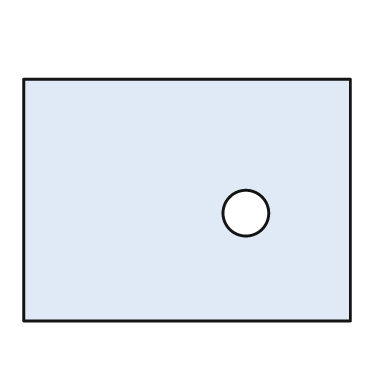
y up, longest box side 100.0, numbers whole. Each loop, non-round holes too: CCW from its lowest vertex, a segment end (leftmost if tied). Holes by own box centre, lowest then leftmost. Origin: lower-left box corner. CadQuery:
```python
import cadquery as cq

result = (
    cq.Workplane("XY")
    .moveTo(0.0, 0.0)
    .lineTo(100.0, 0.0)
    .lineTo(100.0, 74.0)
    .lineTo(0.0, 74.0)
    .close()
    .moveTo(68.0, 33.0)
    .circle(7.0)
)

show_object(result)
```